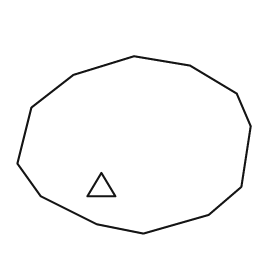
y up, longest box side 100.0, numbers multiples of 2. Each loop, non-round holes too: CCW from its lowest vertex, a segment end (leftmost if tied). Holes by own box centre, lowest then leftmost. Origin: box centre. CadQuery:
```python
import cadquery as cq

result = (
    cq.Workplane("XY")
    .moveTo(4.0, -38.0)
    .lineTo(32.0, -30.0)
    .lineTo(46.0, -18.0)
    .lineTo(50.0, 8.0)
    .lineTo(44.0, 22.0)
    .lineTo(24.0, 34.0)
    .lineTo(0.0, 38.0)
    .lineTo(-26.0, 30.0)
    .lineTo(-44.0, 16.0)
    .lineTo(-50.0, -8.0)
    .lineTo(-40.0, -22.0)
    .lineTo(-16.0, -34.0)
    .close()
    .moveTo(-20.0, -22.0)
    .lineTo(-8.0, -22.0)
    .lineTo(-14.0, -12.0)
    .close()
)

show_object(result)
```